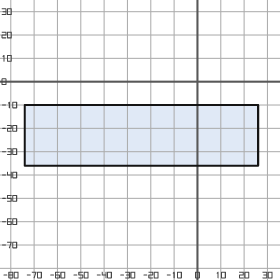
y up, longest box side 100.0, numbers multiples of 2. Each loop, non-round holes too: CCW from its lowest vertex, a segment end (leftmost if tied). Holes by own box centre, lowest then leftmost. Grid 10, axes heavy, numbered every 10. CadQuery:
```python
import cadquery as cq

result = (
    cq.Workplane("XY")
    .moveTo(-74.0, -36.0)
    .lineTo(26.0, -36.0)
    .lineTo(26.0, -10.0)
    .lineTo(-74.0, -10.0)
    .close()
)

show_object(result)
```